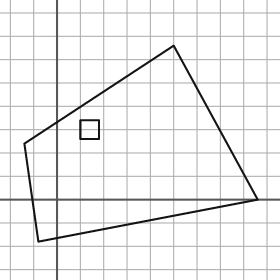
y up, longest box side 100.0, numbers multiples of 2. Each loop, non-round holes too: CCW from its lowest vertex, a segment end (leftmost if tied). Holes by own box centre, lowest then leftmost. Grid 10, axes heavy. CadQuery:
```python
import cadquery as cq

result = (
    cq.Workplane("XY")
    .moveTo(-8.0, -18.0)
    .lineTo(86.0, 0.0)
    .lineTo(50.0, 66.0)
    .lineTo(-14.0, 24.0)
    .close()
    .moveTo(10.0, 26.0)
    .lineTo(18.0, 26.0)
    .lineTo(18.0, 34.0)
    .lineTo(10.0, 34.0)
    .close()
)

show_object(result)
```